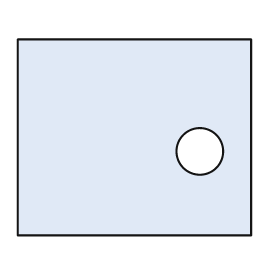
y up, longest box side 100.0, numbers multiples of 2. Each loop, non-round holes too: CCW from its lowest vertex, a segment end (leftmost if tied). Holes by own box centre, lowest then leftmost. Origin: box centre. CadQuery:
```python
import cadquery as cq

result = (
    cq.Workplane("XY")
    .moveTo(-50.0, -42.0)
    .lineTo(50.0, -42.0)
    .lineTo(50.0, 42.0)
    .lineTo(-50.0, 42.0)
    .close()
    .moveTo(28.0, -6.0)
    .circle(10.0)
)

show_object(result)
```